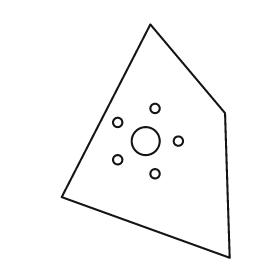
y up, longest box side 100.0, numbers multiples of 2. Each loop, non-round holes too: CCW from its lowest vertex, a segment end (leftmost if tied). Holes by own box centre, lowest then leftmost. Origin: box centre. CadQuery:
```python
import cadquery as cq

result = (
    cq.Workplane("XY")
    .moveTo(36.0, -50.0)
    .lineTo(34.0, 12.0)
    .lineTo(2.0, 50.0)
    .lineTo(-36.0, -24.0)
    .close()
    .moveTo(4.0, -14.0)
    .circle(2.0)
    .moveTo(-12.0, -8.0)
    .circle(2.0)
    .moveTo(0.0, 0.0)
    .circle(6.0)
    .moveTo(14.0, 0.0)
    .circle(2.0)
    .moveTo(-12.0, 8.0)
    .circle(2.0)
    .moveTo(4.0, 14.0)
    .circle(2.0)
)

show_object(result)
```